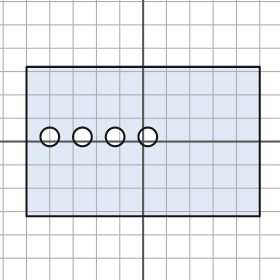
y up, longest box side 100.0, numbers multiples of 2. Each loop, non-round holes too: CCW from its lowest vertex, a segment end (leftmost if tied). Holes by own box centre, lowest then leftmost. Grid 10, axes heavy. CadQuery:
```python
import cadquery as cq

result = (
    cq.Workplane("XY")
    .moveTo(-50.0, -32.0)
    .lineTo(50.0, -32.0)
    .lineTo(50.0, 32.0)
    .lineTo(-50.0, 32.0)
    .close()
    .moveTo(-40.0, 2.0)
    .circle(4.0)
    .moveTo(-26.0, 2.0)
    .circle(4.0)
    .moveTo(-12.0, 2.0)
    .circle(4.0)
    .moveTo(2.0, 2.0)
    .circle(4.0)
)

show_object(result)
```